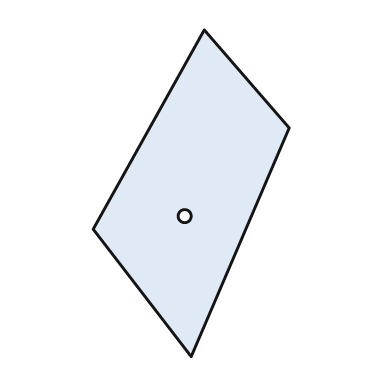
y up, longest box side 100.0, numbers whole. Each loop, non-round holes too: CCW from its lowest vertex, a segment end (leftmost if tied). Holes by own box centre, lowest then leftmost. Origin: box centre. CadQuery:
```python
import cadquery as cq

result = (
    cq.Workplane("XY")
    .moveTo(0.0, -50.0)
    .lineTo(30.0, 20.0)
    .lineTo(4.0, 50.0)
    .lineTo(-30.0, -11.0)
    .close()
    .moveTo(-2.0, -7.0)
    .circle(2.0)
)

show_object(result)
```